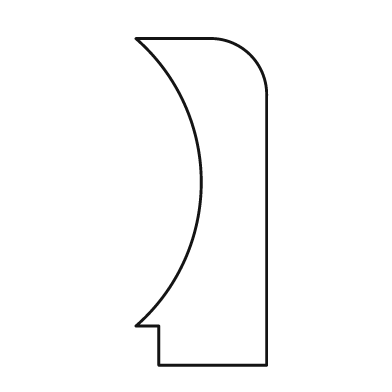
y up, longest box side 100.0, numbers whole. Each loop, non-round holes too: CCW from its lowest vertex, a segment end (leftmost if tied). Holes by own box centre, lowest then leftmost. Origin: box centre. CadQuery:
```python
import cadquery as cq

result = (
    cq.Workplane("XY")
    .moveTo(-13.0, -50.0)
    .lineTo(20.0, -50.0)
    .lineTo(20.0, 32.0)
    .threePointArc((15.0, 45.0), (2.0, 50.0))
    .lineTo(-20.0, 50.0)
    .threePointArc((0.0, 6.0), (-20.0, -38.0))
    .lineTo(-13.0, -38.0)
    .close()
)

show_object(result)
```